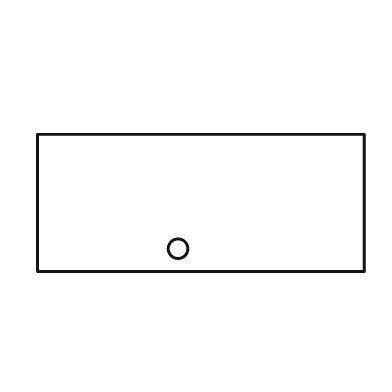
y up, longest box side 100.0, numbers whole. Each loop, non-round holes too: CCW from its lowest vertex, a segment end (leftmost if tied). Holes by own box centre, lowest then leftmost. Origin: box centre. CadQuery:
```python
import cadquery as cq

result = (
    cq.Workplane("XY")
    .moveTo(-50.0, -21.0)
    .lineTo(50.0, -21.0)
    .lineTo(50.0, 21.0)
    .lineTo(-50.0, 21.0)
    .close()
    .moveTo(-7.0, -14.0)
    .circle(3.0)
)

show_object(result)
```